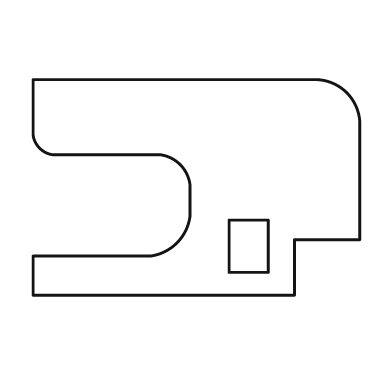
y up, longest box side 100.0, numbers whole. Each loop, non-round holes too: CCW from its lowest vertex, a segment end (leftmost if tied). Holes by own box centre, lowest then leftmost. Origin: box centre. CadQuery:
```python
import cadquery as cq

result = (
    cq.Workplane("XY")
    .moveTo(-50.0, -33.0)
    .lineTo(30.0, -33.0)
    .lineTo(30.0, -16.0)
    .lineTo(50.0, -16.0)
    .lineTo(50.0, 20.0)
    .threePointArc((46.0, 29.0), (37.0, 33.0))
    .lineTo(-50.0, 33.0)
    .lineTo(-50.0, 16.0)
    .threePointArc((-48.0, 12.0), (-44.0, 10.0))
    .lineTo(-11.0, 10.0)
    .threePointArc((-5.0, 7.0), (-2.0, 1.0))
    .lineTo(-2.0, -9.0)
    .threePointArc((-6.0, -17.0), (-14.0, -21.0))
    .lineTo(-50.0, -21.0)
    .close()
    .moveTo(10.0, -26.0)
    .lineTo(22.0, -26.0)
    .lineTo(22.0, -10.0)
    .lineTo(10.0, -10.0)
    .close()
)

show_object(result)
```